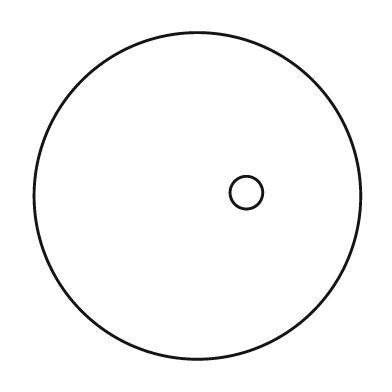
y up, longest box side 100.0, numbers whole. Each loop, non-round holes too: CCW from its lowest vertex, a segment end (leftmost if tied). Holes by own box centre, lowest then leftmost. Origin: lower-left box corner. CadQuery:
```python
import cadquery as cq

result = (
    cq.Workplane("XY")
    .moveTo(50.0, 50.0)
    .circle(50.0)
    .moveTo(65.0, 51.0)
    .circle(5.0)
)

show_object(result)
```